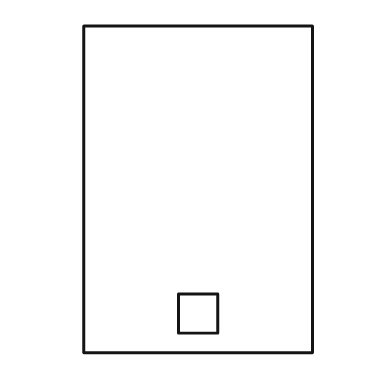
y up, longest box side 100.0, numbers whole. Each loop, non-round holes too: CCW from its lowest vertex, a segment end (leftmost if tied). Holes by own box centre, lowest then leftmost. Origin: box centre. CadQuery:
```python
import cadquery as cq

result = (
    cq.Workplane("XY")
    .moveTo(-35.0, -50.0)
    .lineTo(35.0, -50.0)
    .lineTo(35.0, 50.0)
    .lineTo(-35.0, 50.0)
    .close()
    .moveTo(-6.0, -44.0)
    .lineTo(6.0, -44.0)
    .lineTo(6.0, -32.0)
    .lineTo(-6.0, -32.0)
    .close()
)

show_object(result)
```